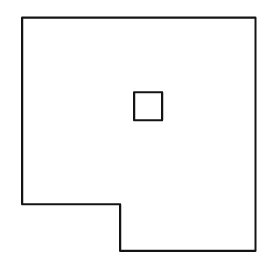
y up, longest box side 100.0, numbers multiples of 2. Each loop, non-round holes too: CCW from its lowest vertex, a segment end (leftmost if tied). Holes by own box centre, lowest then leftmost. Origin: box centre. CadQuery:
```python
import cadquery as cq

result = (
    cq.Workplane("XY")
    .moveTo(-8.0, -50.0)
    .lineTo(50.0, -50.0)
    .lineTo(50.0, 50.0)
    .lineTo(-50.0, 50.0)
    .lineTo(-50.0, -30.0)
    .lineTo(-8.0, -30.0)
    .close()
    .moveTo(-2.0, 6.0)
    .lineTo(10.0, 6.0)
    .lineTo(10.0, 18.0)
    .lineTo(-2.0, 18.0)
    .close()
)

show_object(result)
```